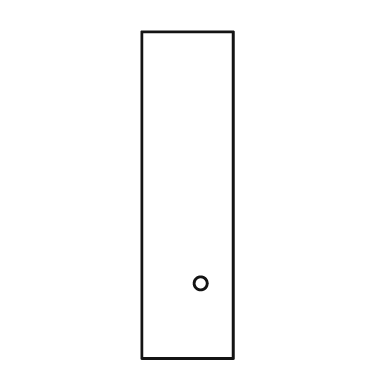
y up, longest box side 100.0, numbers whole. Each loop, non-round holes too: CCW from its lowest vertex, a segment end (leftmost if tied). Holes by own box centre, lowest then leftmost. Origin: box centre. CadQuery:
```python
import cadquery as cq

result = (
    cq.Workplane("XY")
    .moveTo(-14.0, -50.0)
    .lineTo(14.0, -50.0)
    .lineTo(14.0, 50.0)
    .lineTo(-14.0, 50.0)
    .close()
    .moveTo(4.0, -27.0)
    .circle(2.0)
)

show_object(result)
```